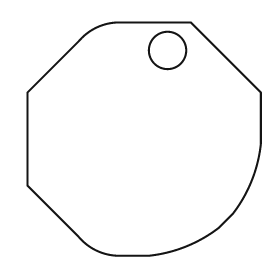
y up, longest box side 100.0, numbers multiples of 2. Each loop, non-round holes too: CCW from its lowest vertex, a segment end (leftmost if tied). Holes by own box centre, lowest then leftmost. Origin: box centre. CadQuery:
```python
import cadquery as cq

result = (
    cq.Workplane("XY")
    .moveTo(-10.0, -50.0)
    .lineTo(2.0, -50.0)
    .threePointArc((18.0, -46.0), (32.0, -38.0))
    .lineTo(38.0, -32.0)
    .threePointArc((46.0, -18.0), (50.0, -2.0))
    .lineTo(50.0, 20.0)
    .lineTo(20.0, 50.0)
    .lineTo(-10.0, 50.0)
    .threePointArc((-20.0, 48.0), (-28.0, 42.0))
    .lineTo(-50.0, 20.0)
    .lineTo(-50.0, -20.0)
    .lineTo(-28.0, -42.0)
    .threePointArc((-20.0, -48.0), (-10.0, -50.0))
    .close()
    .moveTo(10.0, 38.0)
    .circle(8.0)
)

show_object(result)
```